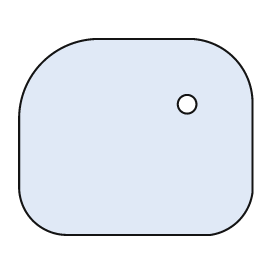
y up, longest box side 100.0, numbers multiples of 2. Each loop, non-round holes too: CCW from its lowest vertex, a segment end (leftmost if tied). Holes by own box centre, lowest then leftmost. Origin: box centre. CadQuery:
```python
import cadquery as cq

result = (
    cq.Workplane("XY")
    .moveTo(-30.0, -42.0)
    .lineTo(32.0, -42.0)
    .threePointArc((44.0, -36.0), (50.0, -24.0))
    .lineTo(50.0, 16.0)
    .threePointArc((42.0, 34.0), (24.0, 42.0))
    .lineTo(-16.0, 42.0)
    .threePointArc((-40.0, 32.0), (-50.0, 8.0))
    .lineTo(-50.0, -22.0)
    .threePointArc((-44.0, -36.0), (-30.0, -42.0))
    .close()
    .moveTo(22.0, 14.0)
    .circle(4.0)
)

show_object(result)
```